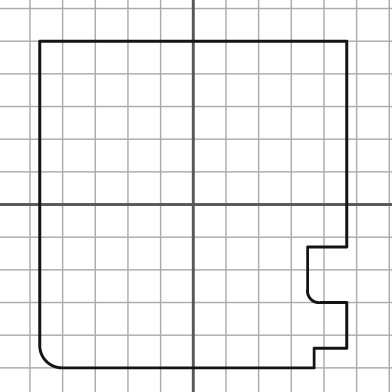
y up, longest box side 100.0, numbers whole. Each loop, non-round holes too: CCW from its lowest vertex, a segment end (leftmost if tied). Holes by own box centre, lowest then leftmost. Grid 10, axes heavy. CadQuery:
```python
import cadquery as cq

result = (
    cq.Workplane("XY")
    .moveTo(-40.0, -50.0)
    .lineTo(37.0, -50.0)
    .lineTo(37.0, -44.0)
    .lineTo(47.0, -44.0)
    .lineTo(47.0, -30.0)
    .lineTo(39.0, -30.0)
    .threePointArc((36.0, -29.0), (35.0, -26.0))
    .lineTo(35.0, -13.0)
    .lineTo(47.0, -13.0)
    .lineTo(47.0, 50.0)
    .lineTo(-47.0, 50.0)
    .lineTo(-47.0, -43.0)
    .threePointArc((-45.0, -48.0), (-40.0, -50.0))
    .close()
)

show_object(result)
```